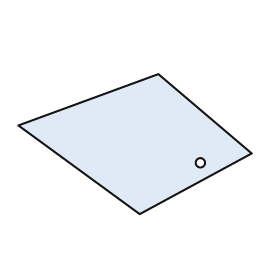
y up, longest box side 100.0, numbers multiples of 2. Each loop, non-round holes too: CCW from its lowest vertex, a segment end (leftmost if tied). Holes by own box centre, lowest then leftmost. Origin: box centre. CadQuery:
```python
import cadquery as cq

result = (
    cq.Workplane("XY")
    .moveTo(2.0, -30.0)
    .lineTo(50.0, -4.0)
    .lineTo(10.0, 30.0)
    .lineTo(-50.0, 8.0)
    .close()
    .moveTo(28.0, -8.0)
    .circle(2.0)
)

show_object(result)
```